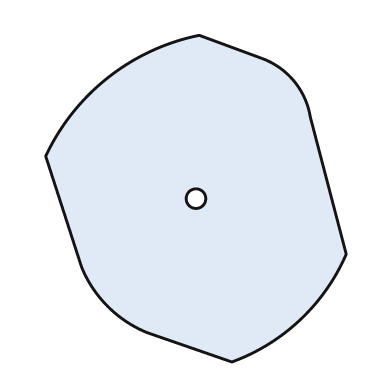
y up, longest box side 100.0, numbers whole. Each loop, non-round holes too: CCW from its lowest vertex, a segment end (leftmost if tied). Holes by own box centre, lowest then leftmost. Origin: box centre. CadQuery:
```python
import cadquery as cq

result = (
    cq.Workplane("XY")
    .moveTo(11.0, -50.0)
    .threePointArc((32.0, -37.0), (46.0, -17.0))
    .lineTo(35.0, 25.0)
    .threePointArc((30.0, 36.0), (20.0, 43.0))
    .lineTo(1.0, 50.0)
    .threePointArc((-27.0, 37.0), (-46.0, 13.0))
    .lineTo(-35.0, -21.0)
    .threePointArc((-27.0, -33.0), (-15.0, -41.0))
    .close()
    .moveTo(0.0, 0.0)
    .circle(3.0)
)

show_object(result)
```